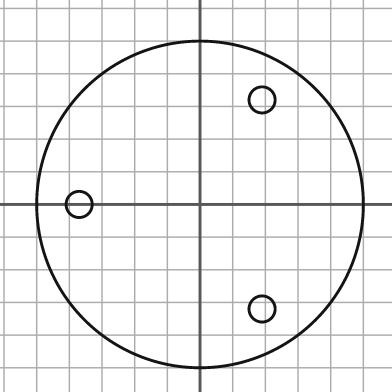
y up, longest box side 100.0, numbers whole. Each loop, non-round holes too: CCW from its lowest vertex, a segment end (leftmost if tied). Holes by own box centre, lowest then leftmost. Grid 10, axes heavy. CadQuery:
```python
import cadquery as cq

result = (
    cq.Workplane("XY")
    .moveTo(0.0, 0.0)
    .circle(50.0)
    .moveTo(19.0, -32.0)
    .circle(4.0)
    .moveTo(-37.0, 0.0)
    .circle(4.0)
    .moveTo(19.0, 32.0)
    .circle(4.0)
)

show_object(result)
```